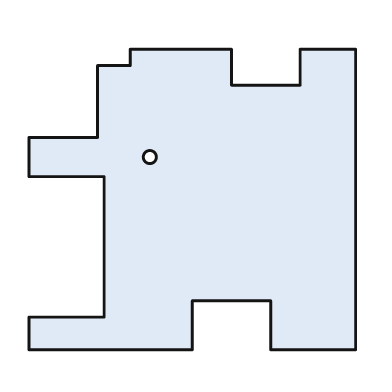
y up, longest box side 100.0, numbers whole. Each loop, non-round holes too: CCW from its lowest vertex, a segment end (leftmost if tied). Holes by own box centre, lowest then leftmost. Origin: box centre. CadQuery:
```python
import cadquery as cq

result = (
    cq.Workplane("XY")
    .moveTo(-50.0, -46.0)
    .lineTo(0.0, -46.0)
    .lineTo(0.0, -31.0)
    .lineTo(24.0, -31.0)
    .lineTo(24.0, -46.0)
    .lineTo(50.0, -46.0)
    .lineTo(50.0, 46.0)
    .lineTo(33.0, 46.0)
    .lineTo(33.0, 35.0)
    .lineTo(12.0, 35.0)
    .lineTo(12.0, 46.0)
    .lineTo(-19.0, 46.0)
    .lineTo(-19.0, 41.0)
    .lineTo(-29.0, 41.0)
    .lineTo(-29.0, 19.0)
    .lineTo(-50.0, 19.0)
    .lineTo(-50.0, 7.0)
    .lineTo(-27.0, 7.0)
    .lineTo(-27.0, -36.0)
    .lineTo(-50.0, -36.0)
    .close()
    .moveTo(-13.0, 13.0)
    .circle(2.0)
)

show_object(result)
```